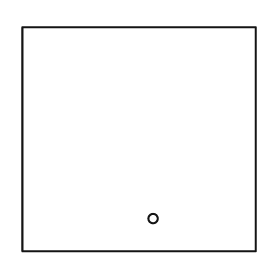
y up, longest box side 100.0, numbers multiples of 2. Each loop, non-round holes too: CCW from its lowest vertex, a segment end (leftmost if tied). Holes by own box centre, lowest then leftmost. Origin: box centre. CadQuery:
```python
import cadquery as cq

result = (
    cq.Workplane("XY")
    .moveTo(-50.0, -48.0)
    .lineTo(50.0, -48.0)
    .lineTo(50.0, 48.0)
    .lineTo(-50.0, 48.0)
    .close()
    .moveTo(6.0, -34.0)
    .circle(2.0)
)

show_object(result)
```